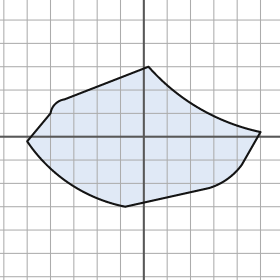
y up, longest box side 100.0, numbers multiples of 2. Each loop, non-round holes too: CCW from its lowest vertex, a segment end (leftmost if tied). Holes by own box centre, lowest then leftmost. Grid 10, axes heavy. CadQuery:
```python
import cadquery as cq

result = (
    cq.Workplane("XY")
    .moveTo(-8.0, -30.0)
    .lineTo(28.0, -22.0)
    .threePointArc((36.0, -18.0), (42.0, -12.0))
    .lineTo(50.0, 2.0)
    .threePointArc((24.0, 12.0), (2.0, 30.0))
    .lineTo(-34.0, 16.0)
    .threePointArc((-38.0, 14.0), (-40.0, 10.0))
    .lineTo(-50.0, -2.0)
    .threePointArc((-32.0, -20.0), (-8.0, -30.0))
    .close()
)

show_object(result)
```